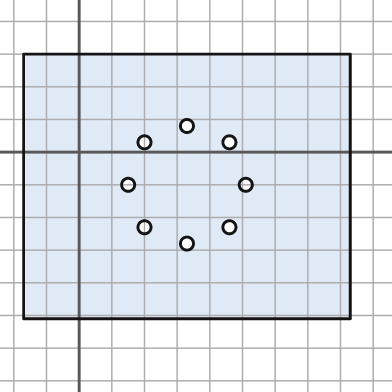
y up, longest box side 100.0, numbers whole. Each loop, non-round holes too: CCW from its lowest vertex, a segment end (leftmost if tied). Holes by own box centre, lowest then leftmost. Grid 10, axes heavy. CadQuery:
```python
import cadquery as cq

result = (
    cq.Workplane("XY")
    .moveTo(-17.0, -51.0)
    .lineTo(83.0, -51.0)
    .lineTo(83.0, 30.0)
    .lineTo(-17.0, 30.0)
    .close()
    .moveTo(33.0, -28.0)
    .circle(2.0)
    .moveTo(20.0, -23.0)
    .circle(2.0)
    .moveTo(46.0, -23.0)
    .circle(2.0)
    .moveTo(15.0, -10.0)
    .circle(2.0)
    .moveTo(51.0, -10.0)
    .circle(2.0)
    .moveTo(20.0, 3.0)
    .circle(2.0)
    .moveTo(46.0, 3.0)
    .circle(2.0)
    .moveTo(33.0, 8.0)
    .circle(2.0)
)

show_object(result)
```